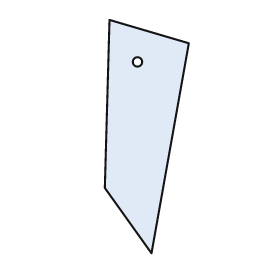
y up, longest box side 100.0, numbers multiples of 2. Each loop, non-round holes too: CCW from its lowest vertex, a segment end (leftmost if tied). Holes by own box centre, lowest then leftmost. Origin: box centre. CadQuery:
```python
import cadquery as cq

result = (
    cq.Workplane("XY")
    .moveTo(2.0, -50.0)
    .lineTo(18.0, 40.0)
    .lineTo(-16.0, 50.0)
    .lineTo(-18.0, -22.0)
    .close()
    .moveTo(-4.0, 32.0)
    .circle(2.0)
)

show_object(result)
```